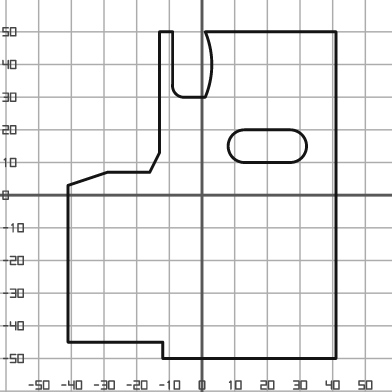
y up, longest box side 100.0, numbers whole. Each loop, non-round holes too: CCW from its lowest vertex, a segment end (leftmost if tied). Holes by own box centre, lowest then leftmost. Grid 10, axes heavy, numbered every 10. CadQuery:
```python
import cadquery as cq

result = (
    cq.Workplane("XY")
    .moveTo(-12.0, -50.0)
    .lineTo(41.0, -50.0)
    .lineTo(41.0, 50.0)
    .lineTo(1.0, 50.0)
    .threePointArc((3.0, 40.0), (1.0, 30.0))
    .lineTo(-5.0, 30.0)
    .threePointArc((-8.0, 31.0), (-9.0, 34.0))
    .lineTo(-9.0, 50.0)
    .lineTo(-13.0, 50.0)
    .lineTo(-13.0, 13.0)
    .lineTo(-16.0, 7.0)
    .lineTo(-29.0, 7.0)
    .lineTo(-41.0, 3.0)
    .lineTo(-41.0, -45.0)
    .lineTo(-12.0, -45.0)
    .close()
    .moveTo(13.0, 10.0)
    .lineTo(27.0, 10.0)
    .threePointArc((32.0, 15.0), (27.0, 20.0))
    .lineTo(13.0, 20.0)
    .threePointArc((8.0, 15.0), (13.0, 10.0))
    .close()
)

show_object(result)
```